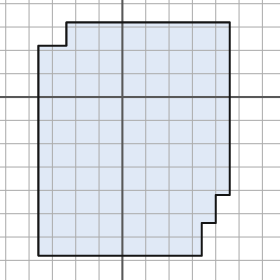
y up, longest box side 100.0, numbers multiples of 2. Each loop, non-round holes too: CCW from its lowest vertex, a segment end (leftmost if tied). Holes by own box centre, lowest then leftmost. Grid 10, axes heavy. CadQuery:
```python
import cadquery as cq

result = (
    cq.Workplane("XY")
    .moveTo(-36.0, -68.0)
    .lineTo(34.0, -68.0)
    .lineTo(34.0, -54.0)
    .lineTo(40.0, -54.0)
    .lineTo(40.0, -42.0)
    .lineTo(46.0, -42.0)
    .lineTo(46.0, 32.0)
    .lineTo(-24.0, 32.0)
    .lineTo(-24.0, 22.0)
    .lineTo(-36.0, 22.0)
    .close()
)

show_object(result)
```